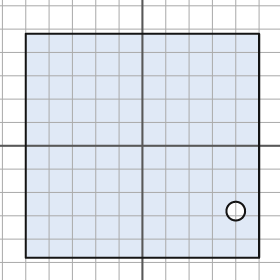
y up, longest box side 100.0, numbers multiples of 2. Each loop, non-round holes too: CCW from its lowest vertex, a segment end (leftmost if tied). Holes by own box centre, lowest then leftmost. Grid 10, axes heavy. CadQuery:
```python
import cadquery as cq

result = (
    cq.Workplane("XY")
    .moveTo(-50.0, -48.0)
    .lineTo(50.0, -48.0)
    .lineTo(50.0, 48.0)
    .lineTo(-50.0, 48.0)
    .close()
    .moveTo(40.0, -28.0)
    .circle(4.0)
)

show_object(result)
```